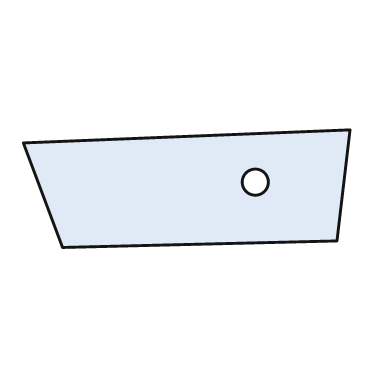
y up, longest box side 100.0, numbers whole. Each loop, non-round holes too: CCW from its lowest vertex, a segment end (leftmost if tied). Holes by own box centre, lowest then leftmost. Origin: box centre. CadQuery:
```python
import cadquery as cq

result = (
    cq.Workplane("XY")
    .moveTo(-38.0, -18.0)
    .lineTo(46.0, -16.0)
    .lineTo(50.0, 18.0)
    .lineTo(-50.0, 14.0)
    .close()
    .moveTo(21.0, 2.0)
    .circle(4.0)
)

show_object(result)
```